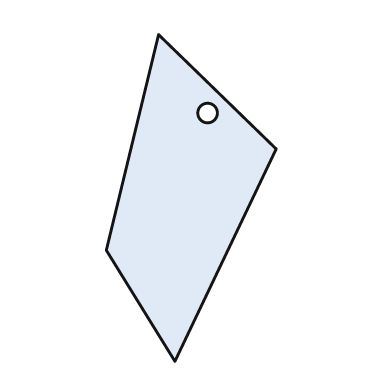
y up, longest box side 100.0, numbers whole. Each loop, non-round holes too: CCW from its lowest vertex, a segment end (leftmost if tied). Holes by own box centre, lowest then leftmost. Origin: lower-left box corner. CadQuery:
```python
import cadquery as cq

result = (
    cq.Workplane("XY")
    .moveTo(21.0, 0.0)
    .lineTo(52.0, 65.0)
    .lineTo(16.0, 100.0)
    .lineTo(0.0, 34.0)
    .close()
    .moveTo(31.0, 76.0)
    .circle(3.0)
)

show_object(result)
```